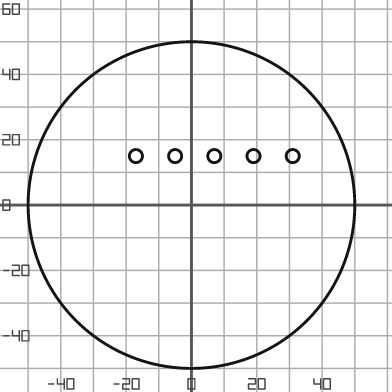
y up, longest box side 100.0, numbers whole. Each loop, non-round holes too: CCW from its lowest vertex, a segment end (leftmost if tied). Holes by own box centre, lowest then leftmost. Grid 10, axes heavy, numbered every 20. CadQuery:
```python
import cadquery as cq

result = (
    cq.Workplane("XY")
    .moveTo(0.0, 0.0)
    .circle(50.0)
    .moveTo(-17.0, 15.0)
    .circle(2.0)
    .moveTo(-5.0, 15.0)
    .circle(2.0)
    .moveTo(7.0, 15.0)
    .circle(2.0)
    .moveTo(19.0, 15.0)
    .circle(2.0)
    .moveTo(31.0, 15.0)
    .circle(2.0)
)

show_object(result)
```